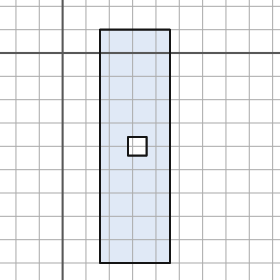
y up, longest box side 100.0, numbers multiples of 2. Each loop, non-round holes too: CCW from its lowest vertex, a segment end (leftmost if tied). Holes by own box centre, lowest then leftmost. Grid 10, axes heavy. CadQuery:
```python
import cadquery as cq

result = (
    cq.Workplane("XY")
    .moveTo(16.0, -90.0)
    .lineTo(46.0, -90.0)
    .lineTo(46.0, 10.0)
    .lineTo(16.0, 10.0)
    .close()
    .moveTo(28.0, -44.0)
    .lineTo(36.0, -44.0)
    .lineTo(36.0, -36.0)
    .lineTo(28.0, -36.0)
    .close()
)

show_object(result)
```